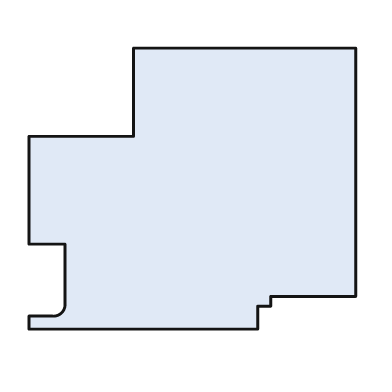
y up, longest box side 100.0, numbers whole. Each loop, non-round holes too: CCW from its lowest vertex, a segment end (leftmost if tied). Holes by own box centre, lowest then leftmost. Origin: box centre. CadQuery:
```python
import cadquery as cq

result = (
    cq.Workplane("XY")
    .moveTo(-50.0, -43.0)
    .lineTo(20.0, -43.0)
    .lineTo(20.0, -36.0)
    .lineTo(24.0, -36.0)
    .lineTo(24.0, -33.0)
    .lineTo(50.0, -33.0)
    .lineTo(50.0, 43.0)
    .lineTo(-18.0, 43.0)
    .lineTo(-18.0, 16.0)
    .lineTo(-50.0, 16.0)
    .lineTo(-50.0, -17.0)
    .lineTo(-39.0, -17.0)
    .lineTo(-39.0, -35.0)
    .threePointArc((-40.0, -38.0), (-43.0, -39.0))
    .lineTo(-50.0, -39.0)
    .close()
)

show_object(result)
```